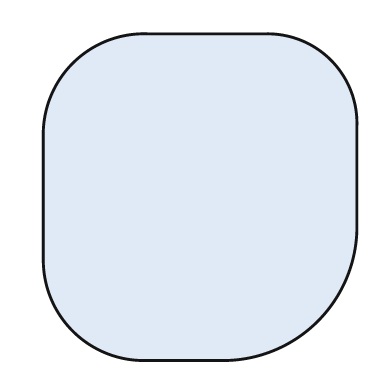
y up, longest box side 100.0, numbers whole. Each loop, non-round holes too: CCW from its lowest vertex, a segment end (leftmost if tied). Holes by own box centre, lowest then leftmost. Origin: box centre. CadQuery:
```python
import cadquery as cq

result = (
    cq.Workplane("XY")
    .moveTo(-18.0, -50.0)
    .lineTo(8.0, -50.0)
    .threePointArc((36.0, -38.0), (48.0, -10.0))
    .lineTo(48.0, 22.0)
    .threePointArc((40.0, 42.0), (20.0, 50.0))
    .lineTo(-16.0, 50.0)
    .threePointArc((-39.0, 41.0), (-48.0, 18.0))
    .lineTo(-48.0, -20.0)
    .threePointArc((-39.0, -41.0), (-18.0, -50.0))
    .close()
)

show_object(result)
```